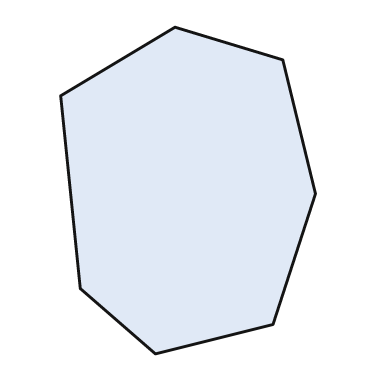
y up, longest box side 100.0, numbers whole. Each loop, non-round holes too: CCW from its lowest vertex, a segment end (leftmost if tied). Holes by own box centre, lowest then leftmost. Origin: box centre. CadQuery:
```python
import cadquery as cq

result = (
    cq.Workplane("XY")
    .moveTo(-10.0, -50.0)
    .lineTo(26.0, -41.0)
    .lineTo(39.0, -1.0)
    .lineTo(29.0, 40.0)
    .lineTo(-4.0, 50.0)
    .lineTo(-39.0, 29.0)
    .lineTo(-33.0, -30.0)
    .close()
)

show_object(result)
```